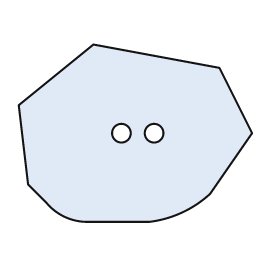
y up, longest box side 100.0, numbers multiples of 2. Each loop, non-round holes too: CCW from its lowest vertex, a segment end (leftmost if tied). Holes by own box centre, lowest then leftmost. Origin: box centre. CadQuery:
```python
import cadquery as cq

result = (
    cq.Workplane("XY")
    .moveTo(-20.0, -38.0)
    .lineTo(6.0, -38.0)
    .threePointArc((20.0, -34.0), (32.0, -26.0))
    .lineTo(50.0, 0.0)
    .lineTo(36.0, 28.0)
    .lineTo(-18.0, 38.0)
    .lineTo(-50.0, 12.0)
    .lineTo(-46.0, -22.0)
    .lineTo(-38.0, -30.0)
    .threePointArc((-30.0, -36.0), (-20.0, -38.0))
    .close()
    .moveTo(-6.0, 0.0)
    .circle(4.0)
    .moveTo(8.0, 0.0)
    .circle(4.0)
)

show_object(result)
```